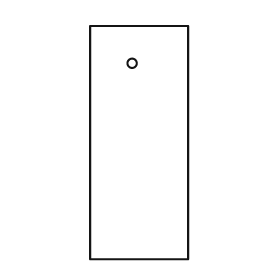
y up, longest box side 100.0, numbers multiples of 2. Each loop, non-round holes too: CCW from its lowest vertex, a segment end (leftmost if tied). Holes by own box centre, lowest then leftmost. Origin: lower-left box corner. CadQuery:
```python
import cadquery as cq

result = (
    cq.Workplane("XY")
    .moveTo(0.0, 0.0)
    .lineTo(42.0, 0.0)
    .lineTo(42.0, 100.0)
    .lineTo(0.0, 100.0)
    .close()
    .moveTo(18.0, 84.0)
    .circle(2.0)
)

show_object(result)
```